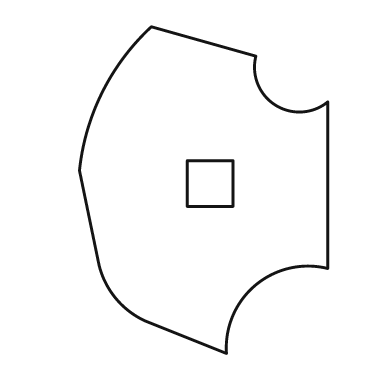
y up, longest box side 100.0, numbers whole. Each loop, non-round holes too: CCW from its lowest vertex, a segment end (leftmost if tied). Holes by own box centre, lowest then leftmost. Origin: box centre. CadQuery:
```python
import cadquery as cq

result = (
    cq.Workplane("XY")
    .moveTo(7.0, -50.0)
    .threePointArc((16.0, -29.0), (38.0, -24.0))
    .lineTo(38.0, 27.0)
    .threePointArc((22.0, 26.0), (16.0, 41.0))
    .lineTo(-16.0, 50.0)
    .threePointArc((-31.0, 30.0), (-38.0, 6.0))
    .lineTo(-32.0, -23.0)
    .threePointArc((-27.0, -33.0), (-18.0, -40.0))
    .close()
    .moveTo(-5.0, -5.0)
    .lineTo(9.0, -5.0)
    .lineTo(9.0, 9.0)
    .lineTo(-5.0, 9.0)
    .close()
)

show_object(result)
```